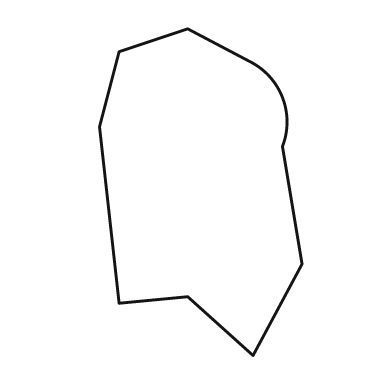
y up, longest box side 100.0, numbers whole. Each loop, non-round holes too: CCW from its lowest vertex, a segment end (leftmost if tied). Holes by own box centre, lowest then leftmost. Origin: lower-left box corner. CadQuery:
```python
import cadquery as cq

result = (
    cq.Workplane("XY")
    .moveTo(47.0, 0.0)
    .lineTo(62.0, 28.0)
    .lineTo(56.0, 64.0)
    .threePointArc((56.0, 79.0), (46.0, 90.0))
    .lineTo(27.0, 100.0)
    .lineTo(6.0, 93.0)
    .lineTo(0.0, 70.0)
    .lineTo(6.0, 16.0)
    .lineTo(27.0, 18.0)
    .close()
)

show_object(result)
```